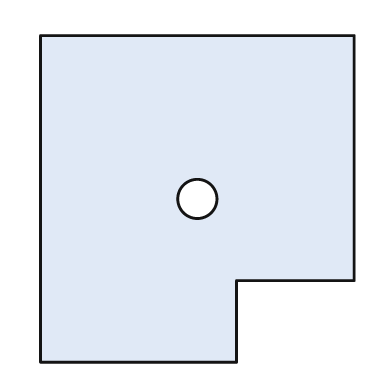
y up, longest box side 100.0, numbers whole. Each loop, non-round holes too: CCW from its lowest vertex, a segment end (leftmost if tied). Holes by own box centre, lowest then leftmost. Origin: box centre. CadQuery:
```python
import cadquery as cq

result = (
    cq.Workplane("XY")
    .moveTo(-48.0, -50.0)
    .lineTo(12.0, -50.0)
    .lineTo(12.0, -25.0)
    .lineTo(48.0, -25.0)
    .lineTo(48.0, 50.0)
    .lineTo(-48.0, 50.0)
    .close()
    .moveTo(0.0, 0.0)
    .circle(6.0)
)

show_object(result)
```